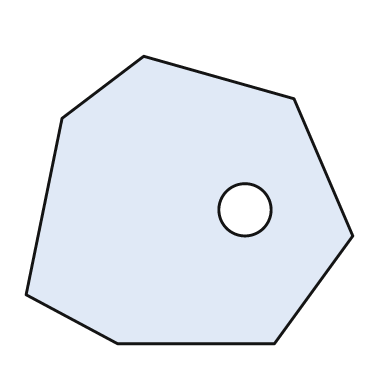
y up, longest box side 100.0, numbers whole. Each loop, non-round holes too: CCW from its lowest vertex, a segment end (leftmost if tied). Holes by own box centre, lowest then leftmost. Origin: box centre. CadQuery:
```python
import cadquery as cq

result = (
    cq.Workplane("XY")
    .moveTo(-22.0, -44.0)
    .lineTo(26.0, -44.0)
    .lineTo(50.0, -11.0)
    .lineTo(32.0, 31.0)
    .lineTo(-14.0, 44.0)
    .lineTo(-39.0, 25.0)
    .lineTo(-50.0, -29.0)
    .close()
    .moveTo(17.0, -3.0)
    .circle(8.0)
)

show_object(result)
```